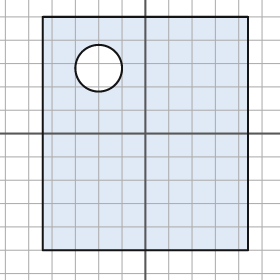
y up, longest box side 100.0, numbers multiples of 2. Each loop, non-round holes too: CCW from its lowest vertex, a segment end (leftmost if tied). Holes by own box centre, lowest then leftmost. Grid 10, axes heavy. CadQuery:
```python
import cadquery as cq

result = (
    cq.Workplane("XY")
    .moveTo(-44.0, -50.0)
    .lineTo(44.0, -50.0)
    .lineTo(44.0, 50.0)
    .lineTo(-44.0, 50.0)
    .close()
    .moveTo(-20.0, 28.0)
    .circle(10.0)
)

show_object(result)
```